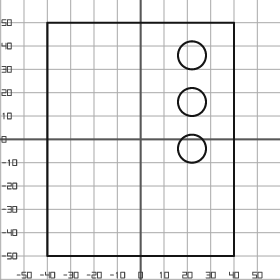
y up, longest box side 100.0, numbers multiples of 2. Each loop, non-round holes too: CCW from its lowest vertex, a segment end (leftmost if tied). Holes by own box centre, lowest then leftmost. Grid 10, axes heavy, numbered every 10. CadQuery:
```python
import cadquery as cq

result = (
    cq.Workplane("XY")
    .moveTo(-40.0, -50.0)
    .lineTo(40.0, -50.0)
    .lineTo(40.0, 50.0)
    .lineTo(-40.0, 50.0)
    .close()
    .moveTo(22.0, -4.0)
    .circle(6.0)
    .moveTo(22.0, 16.0)
    .circle(6.0)
    .moveTo(22.0, 36.0)
    .circle(6.0)
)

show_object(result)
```